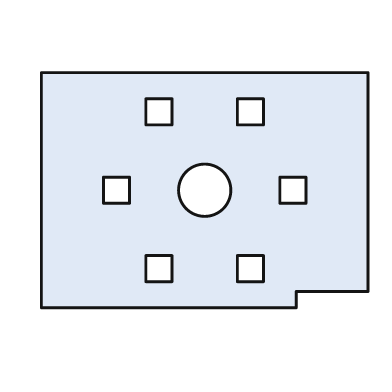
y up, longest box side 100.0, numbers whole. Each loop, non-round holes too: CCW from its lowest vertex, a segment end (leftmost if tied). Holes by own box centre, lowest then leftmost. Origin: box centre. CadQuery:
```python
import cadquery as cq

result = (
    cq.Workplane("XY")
    .moveTo(-50.0, -36.0)
    .lineTo(28.0, -36.0)
    .lineTo(28.0, -31.0)
    .lineTo(50.0, -31.0)
    .lineTo(50.0, 36.0)
    .lineTo(-50.0, 36.0)
    .close()
    .moveTo(-18.0, -28.0)
    .lineTo(-10.0, -28.0)
    .lineTo(-10.0, -20.0)
    .lineTo(-18.0, -20.0)
    .close()
    .moveTo(10.0, -28.0)
    .lineTo(18.0, -28.0)
    .lineTo(18.0, -20.0)
    .lineTo(10.0, -20.0)
    .close()
    .moveTo(-31.0, -4.0)
    .lineTo(-23.0, -4.0)
    .lineTo(-23.0, 4.0)
    .lineTo(-31.0, 4.0)
    .close()
    .moveTo(0.0, 0.0)
    .circle(8.0)
    .moveTo(23.0, -4.0)
    .lineTo(31.0, -4.0)
    .lineTo(31.0, 4.0)
    .lineTo(23.0, 4.0)
    .close()
    .moveTo(-18.0, 20.0)
    .lineTo(-10.0, 20.0)
    .lineTo(-10.0, 28.0)
    .lineTo(-18.0, 28.0)
    .close()
    .moveTo(10.0, 20.0)
    .lineTo(18.0, 20.0)
    .lineTo(18.0, 28.0)
    .lineTo(10.0, 28.0)
    .close()
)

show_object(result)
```